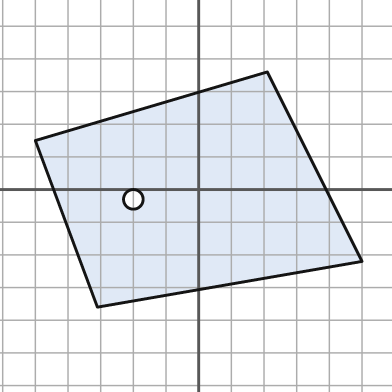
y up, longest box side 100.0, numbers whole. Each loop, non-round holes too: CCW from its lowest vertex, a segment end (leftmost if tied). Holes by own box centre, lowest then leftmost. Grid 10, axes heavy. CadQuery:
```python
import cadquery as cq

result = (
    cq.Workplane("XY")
    .moveTo(-31.0, -36.0)
    .lineTo(50.0, -22.0)
    .lineTo(21.0, 36.0)
    .lineTo(-50.0, 15.0)
    .close()
    .moveTo(-20.0, -3.0)
    .circle(3.0)
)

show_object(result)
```